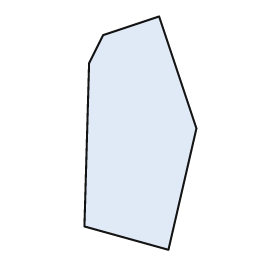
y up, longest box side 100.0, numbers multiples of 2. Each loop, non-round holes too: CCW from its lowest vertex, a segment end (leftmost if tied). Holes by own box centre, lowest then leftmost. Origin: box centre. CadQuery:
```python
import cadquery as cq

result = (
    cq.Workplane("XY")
    .moveTo(12.0, -50.0)
    .lineTo(24.0, 2.0)
    .lineTo(8.0, 50.0)
    .lineTo(-16.0, 42.0)
    .lineTo(-22.0, 30.0)
    .lineTo(-24.0, -40.0)
    .close()
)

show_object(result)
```